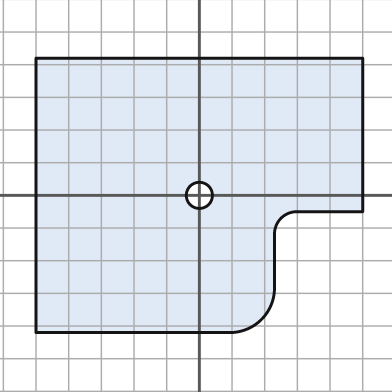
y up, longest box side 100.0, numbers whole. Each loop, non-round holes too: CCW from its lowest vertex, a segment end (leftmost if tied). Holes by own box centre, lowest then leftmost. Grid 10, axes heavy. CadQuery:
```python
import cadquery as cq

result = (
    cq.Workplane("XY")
    .moveTo(-50.0, -42.0)
    .lineTo(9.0, -42.0)
    .threePointArc((19.0, -38.0), (23.0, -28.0))
    .lineTo(23.0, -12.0)
    .threePointArc((25.0, -7.0), (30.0, -5.0))
    .lineTo(50.0, -5.0)
    .lineTo(50.0, 42.0)
    .lineTo(-50.0, 42.0)
    .close()
    .moveTo(0.0, 0.0)
    .circle(4.0)
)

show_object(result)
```